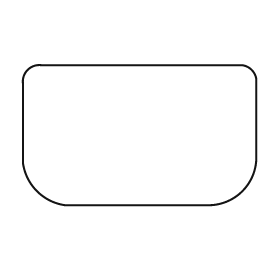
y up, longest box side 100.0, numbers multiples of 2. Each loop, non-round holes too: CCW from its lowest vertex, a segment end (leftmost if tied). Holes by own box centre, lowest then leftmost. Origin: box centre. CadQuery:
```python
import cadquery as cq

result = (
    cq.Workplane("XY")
    .moveTo(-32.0, -30.0)
    .lineTo(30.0, -30.0)
    .threePointArc((44.0, -24.0), (50.0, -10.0))
    .lineTo(50.0, 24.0)
    .threePointArc((48.0, 28.0), (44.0, 30.0))
    .lineTo(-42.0, 30.0)
    .threePointArc((-48.0, 28.0), (-50.0, 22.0))
    .lineTo(-50.0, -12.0)
    .threePointArc((-44.0, -24.0), (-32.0, -30.0))
    .close()
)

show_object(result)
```